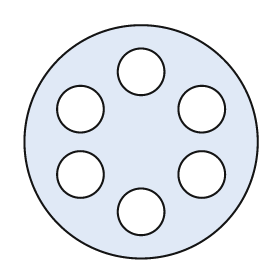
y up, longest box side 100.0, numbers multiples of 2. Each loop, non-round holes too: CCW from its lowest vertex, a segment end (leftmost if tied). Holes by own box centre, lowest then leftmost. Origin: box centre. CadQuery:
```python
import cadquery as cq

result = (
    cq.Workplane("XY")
    .moveTo(0.0, 0.0)
    .circle(50.0)
    .moveTo(0.0, -30.0)
    .circle(10.0)
    .moveTo(-26.0, -14.0)
    .circle(10.0)
    .moveTo(26.0, -14.0)
    .circle(10.0)
    .moveTo(-26.0, 14.0)
    .circle(10.0)
    .moveTo(26.0, 14.0)
    .circle(10.0)
    .moveTo(0.0, 30.0)
    .circle(10.0)
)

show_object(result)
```